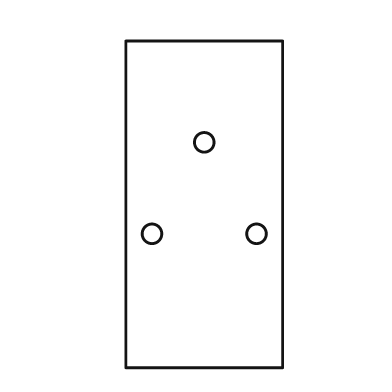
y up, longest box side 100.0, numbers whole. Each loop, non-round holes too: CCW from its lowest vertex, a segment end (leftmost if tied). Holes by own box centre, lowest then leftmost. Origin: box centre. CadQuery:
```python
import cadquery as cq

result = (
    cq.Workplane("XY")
    .moveTo(-24.0, -50.0)
    .lineTo(24.0, -50.0)
    .lineTo(24.0, 50.0)
    .lineTo(-24.0, 50.0)
    .close()
    .moveTo(-16.0, -9.0)
    .circle(3.0)
    .moveTo(16.0, -9.0)
    .circle(3.0)
    .moveTo(0.0, 19.0)
    .circle(3.0)
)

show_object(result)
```